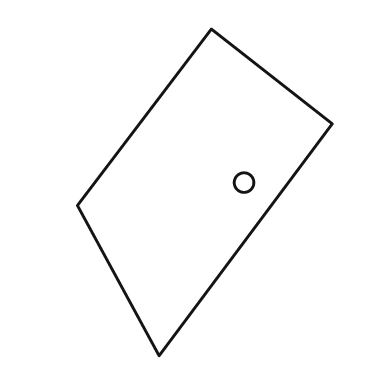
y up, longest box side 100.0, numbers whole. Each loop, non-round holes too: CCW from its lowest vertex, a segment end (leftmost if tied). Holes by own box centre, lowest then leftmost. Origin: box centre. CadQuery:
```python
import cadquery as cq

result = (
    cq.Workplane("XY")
    .moveTo(-14.0, -50.0)
    .lineTo(39.0, 21.0)
    .lineTo(2.0, 50.0)
    .lineTo(-39.0, -4.0)
    .close()
    .moveTo(12.0, 3.0)
    .circle(3.0)
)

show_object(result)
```